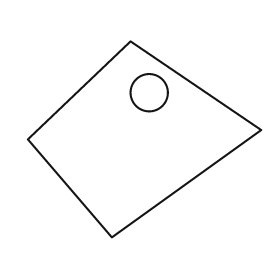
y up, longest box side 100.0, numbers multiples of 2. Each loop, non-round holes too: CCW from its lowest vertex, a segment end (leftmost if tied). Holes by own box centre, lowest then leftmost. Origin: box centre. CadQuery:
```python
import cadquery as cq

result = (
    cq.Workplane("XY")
    .moveTo(-14.0, -42.0)
    .lineTo(50.0, 4.0)
    .lineTo(-6.0, 42.0)
    .lineTo(-50.0, 0.0)
    .close()
    .moveTo(2.0, 20.0)
    .circle(8.0)
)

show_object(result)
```